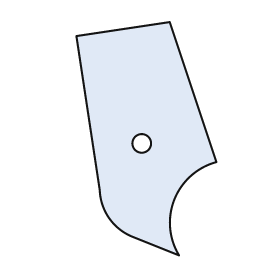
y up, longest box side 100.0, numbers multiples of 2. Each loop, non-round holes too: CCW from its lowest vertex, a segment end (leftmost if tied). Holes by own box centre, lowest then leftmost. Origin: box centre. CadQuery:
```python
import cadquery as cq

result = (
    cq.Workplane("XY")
    .moveTo(14.0, -50.0)
    .threePointArc((12.0, -26.0), (30.0, -10.0))
    .lineTo(10.0, 50.0)
    .lineTo(-30.0, 44.0)
    .lineTo(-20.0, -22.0)
    .threePointArc((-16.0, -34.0), (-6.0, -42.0))
    .close()
    .moveTo(-2.0, -2.0)
    .circle(4.0)
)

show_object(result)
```